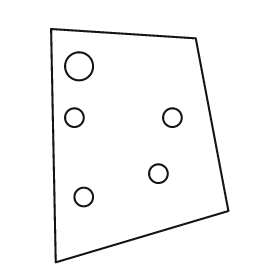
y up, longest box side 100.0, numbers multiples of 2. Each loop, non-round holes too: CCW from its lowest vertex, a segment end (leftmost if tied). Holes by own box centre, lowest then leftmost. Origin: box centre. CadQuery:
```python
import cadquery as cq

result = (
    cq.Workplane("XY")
    .moveTo(-36.0, -50.0)
    .lineTo(38.0, -28.0)
    .lineTo(24.0, 46.0)
    .lineTo(-38.0, 50.0)
    .close()
    .moveTo(-24.0, -22.0)
    .circle(4.0)
    .moveTo(8.0, -12.0)
    .circle(4.0)
    .moveTo(-28.0, 12.0)
    .circle(4.0)
    .moveTo(14.0, 12.0)
    .circle(4.0)
    .moveTo(-26.0, 34.0)
    .circle(6.0)
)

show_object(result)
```